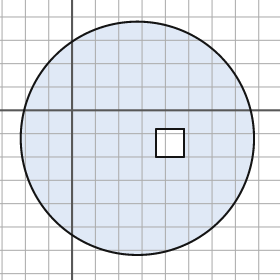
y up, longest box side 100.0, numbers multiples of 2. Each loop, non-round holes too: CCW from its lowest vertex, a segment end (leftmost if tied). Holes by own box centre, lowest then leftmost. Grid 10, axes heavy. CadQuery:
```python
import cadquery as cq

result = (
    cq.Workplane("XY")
    .moveTo(28.0, -12.0)
    .circle(50.0)
    .moveTo(36.0, -20.0)
    .lineTo(48.0, -20.0)
    .lineTo(48.0, -8.0)
    .lineTo(36.0, -8.0)
    .close()
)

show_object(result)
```